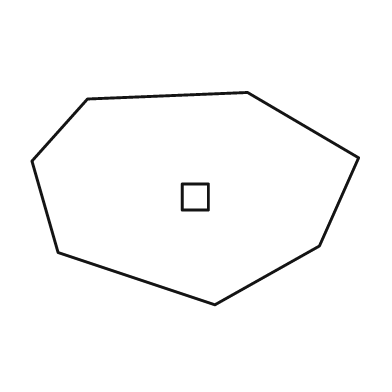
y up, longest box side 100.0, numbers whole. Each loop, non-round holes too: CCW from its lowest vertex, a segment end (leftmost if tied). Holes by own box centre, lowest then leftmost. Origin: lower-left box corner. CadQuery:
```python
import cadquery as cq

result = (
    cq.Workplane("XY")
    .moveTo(56.0, 0.0)
    .lineTo(88.0, 18.0)
    .lineTo(100.0, 45.0)
    .lineTo(66.0, 65.0)
    .lineTo(17.0, 63.0)
    .lineTo(0.0, 44.0)
    .lineTo(8.0, 16.0)
    .close()
    .moveTo(46.0, 29.0)
    .lineTo(54.0, 29.0)
    .lineTo(54.0, 37.0)
    .lineTo(46.0, 37.0)
    .close()
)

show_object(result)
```